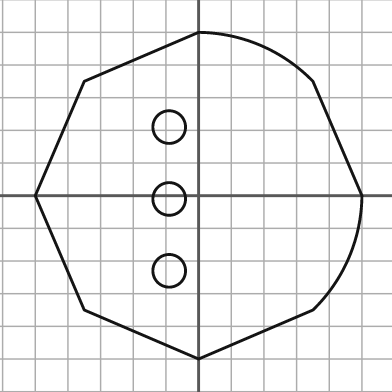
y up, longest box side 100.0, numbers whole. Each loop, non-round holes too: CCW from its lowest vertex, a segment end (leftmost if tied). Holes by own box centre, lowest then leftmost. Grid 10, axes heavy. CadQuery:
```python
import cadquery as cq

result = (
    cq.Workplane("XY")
    .moveTo(0.0, -50.0)
    .lineTo(35.0, -35.0)
    .threePointArc((46.0, -19.0), (50.0, 0.0))
    .lineTo(35.0, 35.0)
    .threePointArc((19.0, 46.0), (0.0, 50.0))
    .lineTo(-35.0, 35.0)
    .lineTo(-50.0, 0.0)
    .lineTo(-35.0, -35.0)
    .close()
    .moveTo(-9.0, -23.0)
    .circle(5.0)
    .moveTo(-9.0, -1.0)
    .circle(5.0)
    .moveTo(-9.0, 21.0)
    .circle(5.0)
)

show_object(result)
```